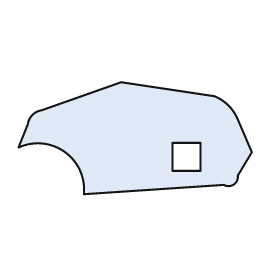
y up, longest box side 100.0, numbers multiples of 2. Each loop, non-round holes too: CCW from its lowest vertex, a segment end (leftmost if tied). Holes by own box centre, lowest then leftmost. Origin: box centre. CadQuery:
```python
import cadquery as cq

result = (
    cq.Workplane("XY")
    .moveTo(-22.0, -24.0)
    .lineTo(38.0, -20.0)
    .threePointArc((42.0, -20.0), (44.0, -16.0))
    .lineTo(50.0, -6.0)
    .lineTo(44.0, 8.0)
    .threePointArc((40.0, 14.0), (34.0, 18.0))
    .lineTo(-6.0, 24.0)
    .lineTo(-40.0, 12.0)
    .threePointArc((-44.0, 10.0), (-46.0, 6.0))
    .lineTo(-50.0, -4.0)
    .threePointArc((-30.0, -6.0), (-22.0, -24.0))
    .close()
    .moveTo(16.0, -14.0)
    .lineTo(28.0, -14.0)
    .lineTo(28.0, -2.0)
    .lineTo(16.0, -2.0)
    .close()
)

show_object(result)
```